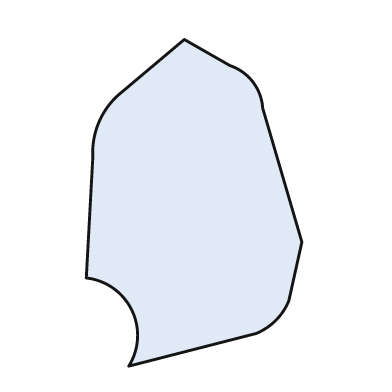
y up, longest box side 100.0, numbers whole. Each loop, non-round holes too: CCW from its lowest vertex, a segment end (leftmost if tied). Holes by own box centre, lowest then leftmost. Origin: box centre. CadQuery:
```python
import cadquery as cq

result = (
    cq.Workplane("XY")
    .moveTo(-20.0, -50.0)
    .lineTo(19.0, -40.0)
    .threePointArc((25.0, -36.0), (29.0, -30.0))
    .lineTo(33.0, -12.0)
    .lineTo(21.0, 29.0)
    .threePointArc((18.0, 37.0), (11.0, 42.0))
    .lineTo(-3.0, 50.0)
    .lineTo(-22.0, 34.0)
    .threePointArc((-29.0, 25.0), (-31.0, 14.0))
    .lineTo(-33.0, -23.0)
    .threePointArc((-19.0, -33.0), (-20.0, -50.0))
    .close()
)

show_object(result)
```